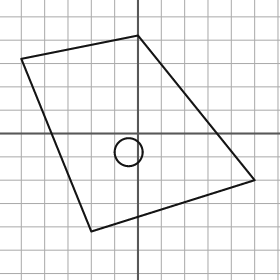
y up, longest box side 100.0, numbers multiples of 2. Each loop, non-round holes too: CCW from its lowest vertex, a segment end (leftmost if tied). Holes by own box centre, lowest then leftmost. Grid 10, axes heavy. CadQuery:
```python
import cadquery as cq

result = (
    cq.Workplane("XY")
    .moveTo(-20.0, -42.0)
    .lineTo(50.0, -20.0)
    .lineTo(0.0, 42.0)
    .lineTo(-50.0, 32.0)
    .close()
    .moveTo(-4.0, -8.0)
    .circle(6.0)
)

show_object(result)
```